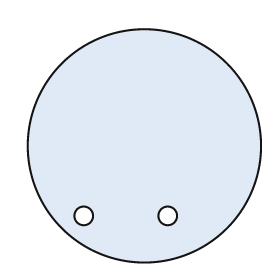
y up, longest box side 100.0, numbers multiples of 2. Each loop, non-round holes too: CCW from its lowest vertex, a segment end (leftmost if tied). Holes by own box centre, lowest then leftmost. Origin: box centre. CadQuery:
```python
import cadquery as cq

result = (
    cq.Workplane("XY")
    .moveTo(0.0, 0.0)
    .circle(50.0)
    .moveTo(-26.0, -30.0)
    .circle(4.0)
    .moveTo(10.0, -30.0)
    .circle(4.0)
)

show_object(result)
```